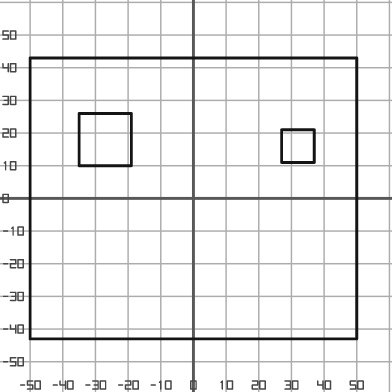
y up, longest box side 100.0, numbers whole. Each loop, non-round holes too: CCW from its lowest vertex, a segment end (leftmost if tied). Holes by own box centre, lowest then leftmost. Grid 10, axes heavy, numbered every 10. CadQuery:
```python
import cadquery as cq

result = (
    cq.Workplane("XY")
    .moveTo(-50.0, -43.0)
    .lineTo(50.0, -43.0)
    .lineTo(50.0, 43.0)
    .lineTo(-50.0, 43.0)
    .close()
    .moveTo(27.0, 11.0)
    .lineTo(37.0, 11.0)
    .lineTo(37.0, 21.0)
    .lineTo(27.0, 21.0)
    .close()
    .moveTo(-35.0, 10.0)
    .lineTo(-19.0, 10.0)
    .lineTo(-19.0, 26.0)
    .lineTo(-35.0, 26.0)
    .close()
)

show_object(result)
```